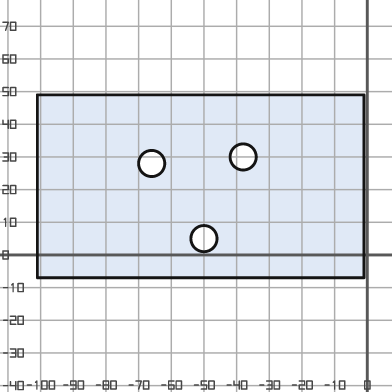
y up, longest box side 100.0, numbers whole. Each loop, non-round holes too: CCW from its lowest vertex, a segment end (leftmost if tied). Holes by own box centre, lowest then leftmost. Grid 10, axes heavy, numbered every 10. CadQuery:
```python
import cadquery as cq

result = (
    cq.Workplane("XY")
    .moveTo(-101.0, -7.0)
    .lineTo(-1.0, -7.0)
    .lineTo(-1.0, 49.0)
    .lineTo(-101.0, 49.0)
    .close()
    .moveTo(-50.0, 5.0)
    .circle(4.0)
    .moveTo(-66.0, 28.0)
    .circle(4.0)
    .moveTo(-38.0, 30.0)
    .circle(4.0)
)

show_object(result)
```